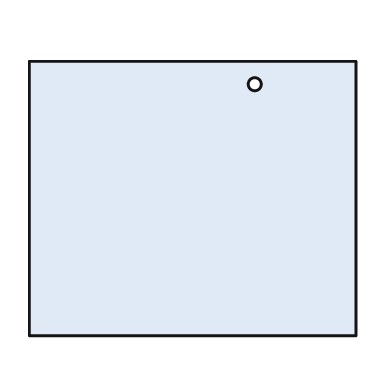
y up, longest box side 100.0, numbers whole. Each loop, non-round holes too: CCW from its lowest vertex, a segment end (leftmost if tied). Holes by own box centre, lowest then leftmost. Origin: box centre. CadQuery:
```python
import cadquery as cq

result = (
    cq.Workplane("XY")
    .moveTo(-50.0, -42.0)
    .lineTo(50.0, -42.0)
    .lineTo(50.0, 42.0)
    .lineTo(-50.0, 42.0)
    .close()
    .moveTo(19.0, 35.0)
    .circle(2.0)
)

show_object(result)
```